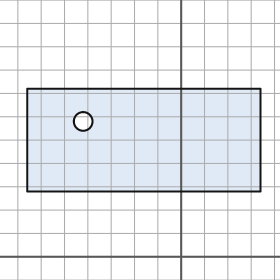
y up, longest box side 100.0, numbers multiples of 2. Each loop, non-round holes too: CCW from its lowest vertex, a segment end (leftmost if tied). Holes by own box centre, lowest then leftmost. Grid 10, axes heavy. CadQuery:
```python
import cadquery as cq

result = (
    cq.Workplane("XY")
    .moveTo(-66.0, 28.0)
    .lineTo(34.0, 28.0)
    .lineTo(34.0, 72.0)
    .lineTo(-66.0, 72.0)
    .close()
    .moveTo(-42.0, 58.0)
    .circle(4.0)
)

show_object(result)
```